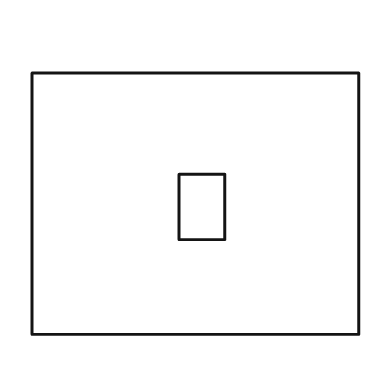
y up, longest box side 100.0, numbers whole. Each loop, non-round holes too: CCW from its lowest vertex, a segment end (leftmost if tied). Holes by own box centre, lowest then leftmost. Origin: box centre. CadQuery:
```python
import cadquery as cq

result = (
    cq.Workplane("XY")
    .moveTo(-50.0, -40.0)
    .lineTo(50.0, -40.0)
    .lineTo(50.0, 40.0)
    .lineTo(-50.0, 40.0)
    .close()
    .moveTo(-5.0, -11.0)
    .lineTo(9.0, -11.0)
    .lineTo(9.0, 9.0)
    .lineTo(-5.0, 9.0)
    .close()
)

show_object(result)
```